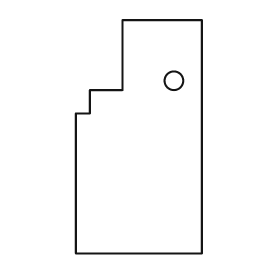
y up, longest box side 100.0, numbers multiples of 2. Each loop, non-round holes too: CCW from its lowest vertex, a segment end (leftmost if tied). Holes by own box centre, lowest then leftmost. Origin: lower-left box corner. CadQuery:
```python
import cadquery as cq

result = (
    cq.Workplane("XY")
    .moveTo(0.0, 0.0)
    .lineTo(54.0, 0.0)
    .lineTo(54.0, 100.0)
    .lineTo(20.0, 100.0)
    .lineTo(20.0, 70.0)
    .lineTo(6.0, 70.0)
    .lineTo(6.0, 60.0)
    .lineTo(0.0, 60.0)
    .close()
    .moveTo(42.0, 74.0)
    .circle(4.0)
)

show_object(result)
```